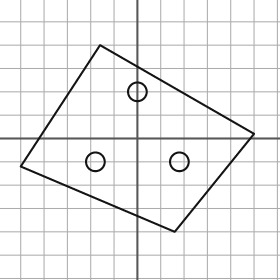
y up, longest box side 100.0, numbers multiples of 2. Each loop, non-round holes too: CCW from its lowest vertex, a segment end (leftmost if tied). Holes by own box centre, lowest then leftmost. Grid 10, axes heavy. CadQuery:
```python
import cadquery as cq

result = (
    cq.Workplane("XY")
    .moveTo(16.0, -40.0)
    .lineTo(50.0, 2.0)
    .lineTo(-16.0, 40.0)
    .lineTo(-50.0, -12.0)
    .close()
    .moveTo(-18.0, -10.0)
    .circle(4.0)
    .moveTo(18.0, -10.0)
    .circle(4.0)
    .moveTo(0.0, 20.0)
    .circle(4.0)
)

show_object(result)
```